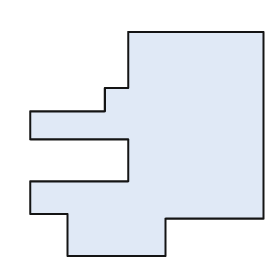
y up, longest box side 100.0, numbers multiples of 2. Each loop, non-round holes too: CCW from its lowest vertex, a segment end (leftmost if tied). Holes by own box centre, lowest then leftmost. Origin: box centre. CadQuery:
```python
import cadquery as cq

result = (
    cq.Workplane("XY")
    .moveTo(-34.0, -48.0)
    .lineTo(8.0, -48.0)
    .lineTo(8.0, -32.0)
    .lineTo(50.0, -32.0)
    .lineTo(50.0, 48.0)
    .lineTo(-8.0, 48.0)
    .lineTo(-8.0, 24.0)
    .lineTo(-18.0, 24.0)
    .lineTo(-18.0, 14.0)
    .lineTo(-50.0, 14.0)
    .lineTo(-50.0, 2.0)
    .lineTo(-8.0, 2.0)
    .lineTo(-8.0, -16.0)
    .lineTo(-50.0, -16.0)
    .lineTo(-50.0, -30.0)
    .lineTo(-34.0, -30.0)
    .close()
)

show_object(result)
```